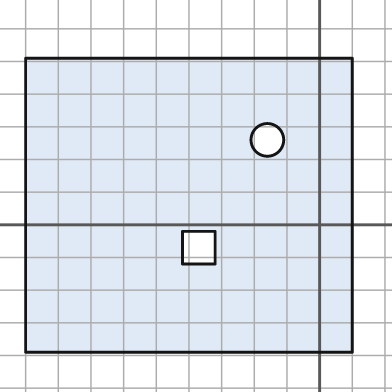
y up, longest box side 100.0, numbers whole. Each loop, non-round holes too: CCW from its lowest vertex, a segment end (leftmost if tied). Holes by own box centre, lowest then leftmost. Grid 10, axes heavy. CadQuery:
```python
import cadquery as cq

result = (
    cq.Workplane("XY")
    .moveTo(-90.0, -39.0)
    .lineTo(10.0, -39.0)
    .lineTo(10.0, 51.0)
    .lineTo(-90.0, 51.0)
    .close()
    .moveTo(-42.0, -12.0)
    .lineTo(-32.0, -12.0)
    .lineTo(-32.0, -2.0)
    .lineTo(-42.0, -2.0)
    .close()
    .moveTo(-16.0, 26.0)
    .circle(5.0)
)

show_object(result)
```